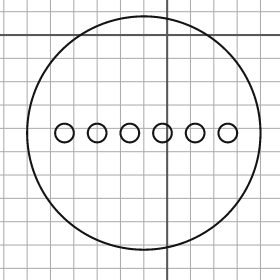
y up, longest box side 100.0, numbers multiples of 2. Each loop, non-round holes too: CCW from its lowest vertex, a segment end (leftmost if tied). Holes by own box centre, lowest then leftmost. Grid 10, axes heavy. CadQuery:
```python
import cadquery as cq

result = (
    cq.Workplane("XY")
    .moveTo(-10.0, -42.0)
    .circle(50.0)
    .moveTo(-44.0, -42.0)
    .circle(4.0)
    .moveTo(-30.0, -42.0)
    .circle(4.0)
    .moveTo(-16.0, -42.0)
    .circle(4.0)
    .moveTo(-2.0, -42.0)
    .circle(4.0)
    .moveTo(12.0, -42.0)
    .circle(4.0)
    .moveTo(26.0, -42.0)
    .circle(4.0)
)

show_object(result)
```